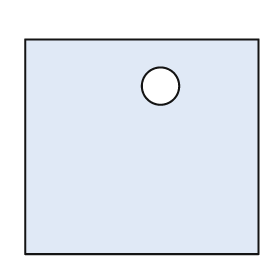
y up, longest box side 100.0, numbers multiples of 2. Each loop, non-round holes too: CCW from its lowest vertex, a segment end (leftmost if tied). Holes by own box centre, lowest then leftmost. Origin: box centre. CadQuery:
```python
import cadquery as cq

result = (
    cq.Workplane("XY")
    .moveTo(-50.0, -46.0)
    .lineTo(50.0, -46.0)
    .lineTo(50.0, 46.0)
    .lineTo(-50.0, 46.0)
    .close()
    .moveTo(8.0, 26.0)
    .circle(8.0)
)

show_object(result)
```